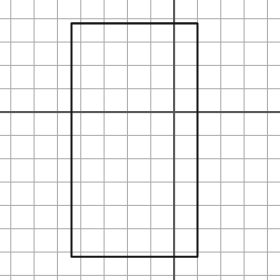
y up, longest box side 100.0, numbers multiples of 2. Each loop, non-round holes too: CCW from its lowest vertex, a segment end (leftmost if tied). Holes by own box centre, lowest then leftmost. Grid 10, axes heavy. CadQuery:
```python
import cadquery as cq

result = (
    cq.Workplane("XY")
    .moveTo(-44.0, -62.0)
    .lineTo(10.0, -62.0)
    .lineTo(10.0, 38.0)
    .lineTo(-44.0, 38.0)
    .close()
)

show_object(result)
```